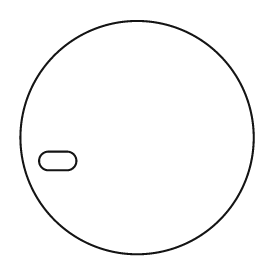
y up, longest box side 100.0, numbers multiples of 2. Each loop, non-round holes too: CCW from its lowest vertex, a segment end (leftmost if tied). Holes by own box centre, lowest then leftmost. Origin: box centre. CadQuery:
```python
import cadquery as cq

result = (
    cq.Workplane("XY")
    .moveTo(0.0, 0.0)
    .circle(50.0)
    .moveTo(-38.0, -14.0)
    .lineTo(-30.0, -14.0)
    .threePointArc((-26.0, -10.0), (-30.0, -6.0))
    .lineTo(-38.0, -6.0)
    .threePointArc((-42.0, -10.0), (-38.0, -14.0))
    .close()
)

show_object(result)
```